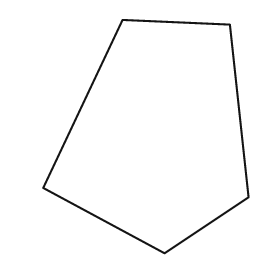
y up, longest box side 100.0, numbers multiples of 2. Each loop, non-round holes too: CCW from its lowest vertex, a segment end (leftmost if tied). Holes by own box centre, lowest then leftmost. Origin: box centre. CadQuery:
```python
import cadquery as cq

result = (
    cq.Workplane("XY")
    .moveTo(8.0, -50.0)
    .lineTo(44.0, -26.0)
    .lineTo(36.0, 48.0)
    .lineTo(-10.0, 50.0)
    .lineTo(-44.0, -22.0)
    .close()
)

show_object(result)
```